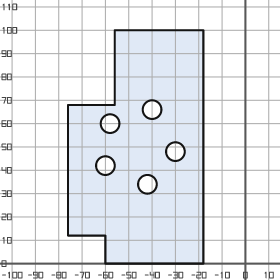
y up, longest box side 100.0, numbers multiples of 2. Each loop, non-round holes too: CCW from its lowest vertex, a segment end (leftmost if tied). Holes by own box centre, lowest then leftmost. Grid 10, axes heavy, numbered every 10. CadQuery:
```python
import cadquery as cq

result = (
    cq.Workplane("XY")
    .moveTo(-60.0, 0.0)
    .lineTo(-18.0, 0.0)
    .lineTo(-18.0, 100.0)
    .lineTo(-56.0, 100.0)
    .lineTo(-56.0, 68.0)
    .lineTo(-76.0, 68.0)
    .lineTo(-76.0, 12.0)
    .lineTo(-60.0, 12.0)
    .close()
    .moveTo(-42.0, 34.0)
    .circle(4.0)
    .moveTo(-60.0, 42.0)
    .circle(4.0)
    .moveTo(-30.0, 48.0)
    .circle(4.0)
    .moveTo(-58.0, 60.0)
    .circle(4.0)
    .moveTo(-40.0, 66.0)
    .circle(4.0)
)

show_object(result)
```